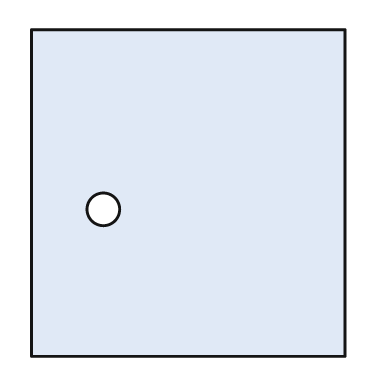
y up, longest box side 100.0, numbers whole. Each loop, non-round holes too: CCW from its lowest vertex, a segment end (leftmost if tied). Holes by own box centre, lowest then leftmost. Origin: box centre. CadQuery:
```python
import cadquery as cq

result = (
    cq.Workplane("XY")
    .moveTo(-48.0, -50.0)
    .lineTo(48.0, -50.0)
    .lineTo(48.0, 50.0)
    .lineTo(-48.0, 50.0)
    .close()
    .moveTo(-26.0, -5.0)
    .circle(5.0)
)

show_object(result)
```